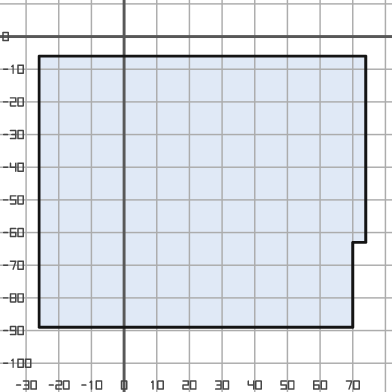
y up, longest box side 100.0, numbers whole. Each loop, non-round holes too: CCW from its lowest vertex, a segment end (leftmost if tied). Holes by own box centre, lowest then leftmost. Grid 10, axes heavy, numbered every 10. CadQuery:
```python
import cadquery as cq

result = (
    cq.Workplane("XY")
    .moveTo(-26.0, -89.0)
    .lineTo(70.0, -89.0)
    .lineTo(70.0, -63.0)
    .lineTo(74.0, -63.0)
    .lineTo(74.0, -6.0)
    .lineTo(-26.0, -6.0)
    .close()
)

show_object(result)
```